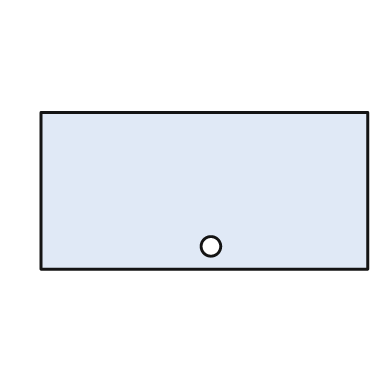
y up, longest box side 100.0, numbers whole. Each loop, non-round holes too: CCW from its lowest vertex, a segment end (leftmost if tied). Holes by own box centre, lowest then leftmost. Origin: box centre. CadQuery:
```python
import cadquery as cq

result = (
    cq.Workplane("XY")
    .moveTo(-50.0, -24.0)
    .lineTo(50.0, -24.0)
    .lineTo(50.0, 24.0)
    .lineTo(-50.0, 24.0)
    .close()
    .moveTo(2.0, -17.0)
    .circle(3.0)
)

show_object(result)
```